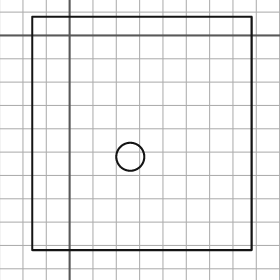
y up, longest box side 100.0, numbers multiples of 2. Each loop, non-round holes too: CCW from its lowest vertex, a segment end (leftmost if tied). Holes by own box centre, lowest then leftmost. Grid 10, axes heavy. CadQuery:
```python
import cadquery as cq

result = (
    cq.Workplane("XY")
    .moveTo(-16.0, -92.0)
    .lineTo(78.0, -92.0)
    .lineTo(78.0, 8.0)
    .lineTo(-16.0, 8.0)
    .close()
    .moveTo(26.0, -52.0)
    .circle(6.0)
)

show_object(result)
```